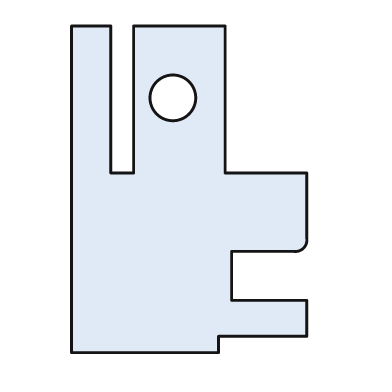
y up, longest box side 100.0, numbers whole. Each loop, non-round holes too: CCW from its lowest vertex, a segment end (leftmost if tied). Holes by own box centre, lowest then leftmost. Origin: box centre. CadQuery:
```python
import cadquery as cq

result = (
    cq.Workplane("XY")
    .moveTo(-36.0, -50.0)
    .lineTo(9.0, -50.0)
    .lineTo(9.0, -45.0)
    .lineTo(36.0, -45.0)
    .lineTo(36.0, -34.0)
    .lineTo(13.0, -34.0)
    .lineTo(13.0, -19.0)
    .lineTo(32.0, -19.0)
    .threePointArc((35.0, -18.0), (36.0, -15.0))
    .lineTo(36.0, 5.0)
    .lineTo(11.0, 5.0)
    .lineTo(11.0, 50.0)
    .lineTo(-17.0, 50.0)
    .lineTo(-17.0, 5.0)
    .lineTo(-24.0, 5.0)
    .lineTo(-24.0, 50.0)
    .lineTo(-36.0, 50.0)
    .close()
    .moveTo(-5.0, 28.0)
    .circle(7.0)
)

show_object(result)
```